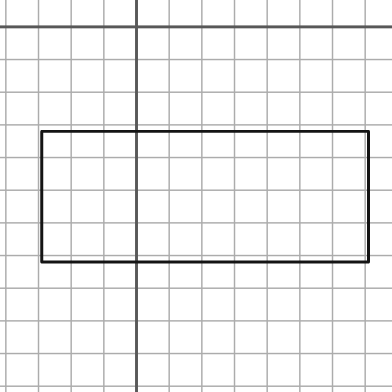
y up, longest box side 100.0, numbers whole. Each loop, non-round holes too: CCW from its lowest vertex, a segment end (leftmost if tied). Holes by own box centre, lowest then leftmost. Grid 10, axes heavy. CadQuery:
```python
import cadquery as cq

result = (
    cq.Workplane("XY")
    .moveTo(-29.0, -72.0)
    .lineTo(71.0, -72.0)
    .lineTo(71.0, -32.0)
    .lineTo(-29.0, -32.0)
    .close()
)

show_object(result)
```